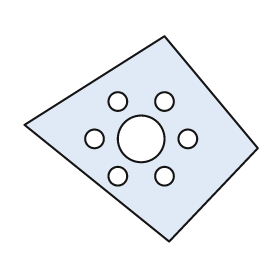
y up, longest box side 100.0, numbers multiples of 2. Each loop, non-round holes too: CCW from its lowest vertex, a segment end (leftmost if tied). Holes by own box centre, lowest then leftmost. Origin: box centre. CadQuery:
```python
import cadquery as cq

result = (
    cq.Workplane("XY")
    .moveTo(12.0, -44.0)
    .lineTo(50.0, -4.0)
    .lineTo(10.0, 44.0)
    .lineTo(-50.0, 6.0)
    .close()
    .moveTo(-10.0, -16.0)
    .circle(4.0)
    .moveTo(10.0, -16.0)
    .circle(4.0)
    .moveTo(-20.0, 0.0)
    .circle(4.0)
    .moveTo(0.0, 0.0)
    .circle(10.0)
    .moveTo(20.0, 0.0)
    .circle(4.0)
    .moveTo(-10.0, 16.0)
    .circle(4.0)
    .moveTo(10.0, 16.0)
    .circle(4.0)
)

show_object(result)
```